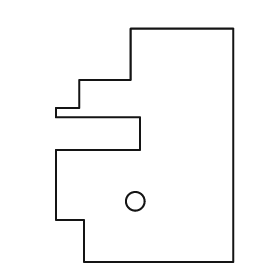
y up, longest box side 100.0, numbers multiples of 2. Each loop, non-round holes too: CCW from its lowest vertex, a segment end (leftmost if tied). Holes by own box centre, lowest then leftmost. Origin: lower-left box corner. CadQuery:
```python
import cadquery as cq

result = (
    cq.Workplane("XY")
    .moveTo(12.0, 0.0)
    .lineTo(76.0, 0.0)
    .lineTo(76.0, 100.0)
    .lineTo(32.0, 100.0)
    .lineTo(32.0, 78.0)
    .lineTo(10.0, 78.0)
    .lineTo(10.0, 66.0)
    .lineTo(0.0, 66.0)
    .lineTo(0.0, 62.0)
    .lineTo(36.0, 62.0)
    .lineTo(36.0, 48.0)
    .lineTo(0.0, 48.0)
    .lineTo(0.0, 18.0)
    .lineTo(12.0, 18.0)
    .close()
    .moveTo(34.0, 26.0)
    .circle(4.0)
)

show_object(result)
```